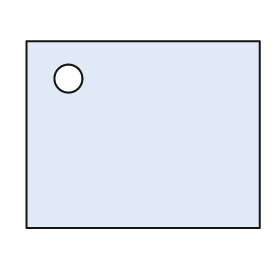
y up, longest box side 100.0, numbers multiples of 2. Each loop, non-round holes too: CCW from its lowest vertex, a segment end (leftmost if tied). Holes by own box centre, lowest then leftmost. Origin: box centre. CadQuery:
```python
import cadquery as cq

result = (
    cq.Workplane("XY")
    .moveTo(-50.0, -40.0)
    .lineTo(50.0, -40.0)
    .lineTo(50.0, 40.0)
    .lineTo(-50.0, 40.0)
    .close()
    .moveTo(-32.0, 24.0)
    .circle(6.0)
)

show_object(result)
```